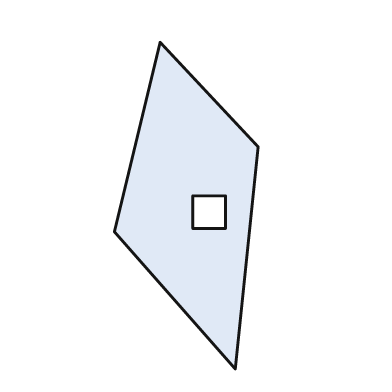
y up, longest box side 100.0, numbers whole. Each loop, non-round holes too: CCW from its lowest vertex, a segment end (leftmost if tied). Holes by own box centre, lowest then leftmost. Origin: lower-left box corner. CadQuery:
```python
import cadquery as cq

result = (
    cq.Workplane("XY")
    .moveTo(37.0, 0.0)
    .lineTo(44.0, 68.0)
    .lineTo(14.0, 100.0)
    .lineTo(0.0, 42.0)
    .close()
    .moveTo(24.0, 43.0)
    .lineTo(34.0, 43.0)
    .lineTo(34.0, 53.0)
    .lineTo(24.0, 53.0)
    .close()
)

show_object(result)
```